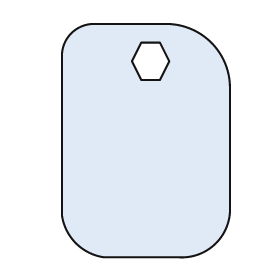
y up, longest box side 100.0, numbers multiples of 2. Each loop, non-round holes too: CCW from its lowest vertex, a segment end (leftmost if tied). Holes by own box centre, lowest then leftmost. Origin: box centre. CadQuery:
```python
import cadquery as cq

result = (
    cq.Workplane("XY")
    .moveTo(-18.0, -50.0)
    .lineTo(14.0, -50.0)
    .threePointArc((30.0, -44.0), (36.0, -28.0))
    .lineTo(36.0, 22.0)
    .threePointArc((28.0, 42.0), (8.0, 50.0))
    .lineTo(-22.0, 50.0)
    .threePointArc((-32.0, 46.0), (-36.0, 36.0))
    .lineTo(-36.0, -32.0)
    .threePointArc((-30.0, -44.0), (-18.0, -50.0))
    .close()
    .moveTo(-2.0, 26.0)
    .lineTo(6.0, 26.0)
    .lineTo(10.0, 34.0)
    .lineTo(6.0, 42.0)
    .lineTo(-2.0, 42.0)
    .lineTo(-6.0, 34.0)
    .close()
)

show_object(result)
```